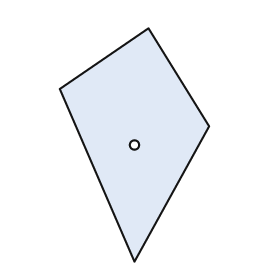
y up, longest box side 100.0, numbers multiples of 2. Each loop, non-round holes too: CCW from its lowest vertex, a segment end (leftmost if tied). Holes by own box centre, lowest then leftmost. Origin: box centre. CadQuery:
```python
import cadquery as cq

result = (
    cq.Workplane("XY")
    .moveTo(0.0, -50.0)
    .lineTo(32.0, 8.0)
    .lineTo(6.0, 50.0)
    .lineTo(-32.0, 24.0)
    .close()
    .moveTo(0.0, 0.0)
    .circle(2.0)
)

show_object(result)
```